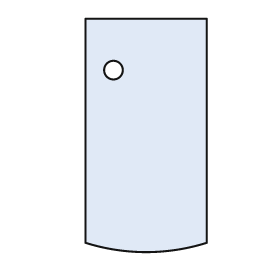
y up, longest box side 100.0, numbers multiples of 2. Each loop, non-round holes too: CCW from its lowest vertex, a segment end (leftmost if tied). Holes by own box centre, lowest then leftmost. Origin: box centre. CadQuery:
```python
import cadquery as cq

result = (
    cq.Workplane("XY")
    .moveTo(-26.0, -46.0)
    .threePointArc((0.0, -50.0), (26.0, -46.0))
    .lineTo(26.0, 50.0)
    .lineTo(-26.0, 50.0)
    .close()
    .moveTo(-14.0, 28.0)
    .circle(4.0)
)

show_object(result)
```